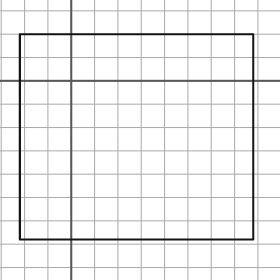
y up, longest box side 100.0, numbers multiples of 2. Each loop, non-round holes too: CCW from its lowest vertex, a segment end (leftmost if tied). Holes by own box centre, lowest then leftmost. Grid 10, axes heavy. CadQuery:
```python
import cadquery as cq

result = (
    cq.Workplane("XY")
    .moveTo(-22.0, -68.0)
    .lineTo(78.0, -68.0)
    .lineTo(78.0, 20.0)
    .lineTo(-22.0, 20.0)
    .close()
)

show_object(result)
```